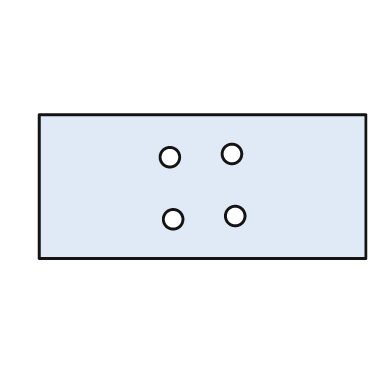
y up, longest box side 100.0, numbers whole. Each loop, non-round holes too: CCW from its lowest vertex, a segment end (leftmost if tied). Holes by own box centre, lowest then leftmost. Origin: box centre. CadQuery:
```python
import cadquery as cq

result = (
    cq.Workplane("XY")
    .moveTo(-50.0, -22.0)
    .lineTo(50.0, -22.0)
    .lineTo(50.0, 22.0)
    .lineTo(-50.0, 22.0)
    .close()
    .moveTo(-9.0, -10.0)
    .circle(3.0)
    .moveTo(10.0, -9.0)
    .circle(3.0)
    .moveTo(-10.0, 9.0)
    .circle(3.0)
    .moveTo(9.0, 10.0)
    .circle(3.0)
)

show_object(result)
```